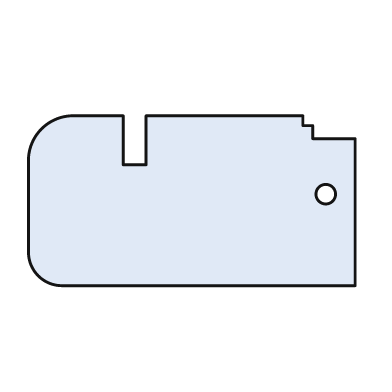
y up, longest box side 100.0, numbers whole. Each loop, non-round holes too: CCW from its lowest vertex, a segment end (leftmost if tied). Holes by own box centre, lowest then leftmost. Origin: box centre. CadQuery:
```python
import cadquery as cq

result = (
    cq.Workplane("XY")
    .moveTo(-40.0, -26.0)
    .lineTo(50.0, -26.0)
    .lineTo(50.0, 19.0)
    .lineTo(37.0, 19.0)
    .lineTo(37.0, 23.0)
    .lineTo(34.0, 23.0)
    .lineTo(34.0, 26.0)
    .lineTo(-14.0, 26.0)
    .lineTo(-14.0, 11.0)
    .lineTo(-21.0, 11.0)
    .lineTo(-21.0, 26.0)
    .lineTo(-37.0, 26.0)
    .threePointArc((-46.0, 22.0), (-50.0, 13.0))
    .lineTo(-50.0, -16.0)
    .threePointArc((-47.0, -23.0), (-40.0, -26.0))
    .close()
    .moveTo(41.0, 2.0)
    .circle(3.0)
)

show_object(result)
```